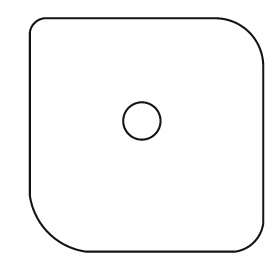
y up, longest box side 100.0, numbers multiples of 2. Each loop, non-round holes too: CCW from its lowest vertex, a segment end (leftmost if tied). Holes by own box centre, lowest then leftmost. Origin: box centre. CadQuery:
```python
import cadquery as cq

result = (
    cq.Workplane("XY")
    .moveTo(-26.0, -50.0)
    .lineTo(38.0, -50.0)
    .threePointArc((46.0, -46.0), (50.0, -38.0))
    .lineTo(50.0, 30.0)
    .threePointArc((44.0, 44.0), (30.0, 50.0))
    .lineTo(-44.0, 50.0)
    .threePointArc((-48.0, 48.0), (-50.0, 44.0))
    .lineTo(-50.0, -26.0)
    .threePointArc((-42.0, -42.0), (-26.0, -50.0))
    .close()
    .moveTo(-2.0, 6.0)
    .circle(8.0)
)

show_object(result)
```